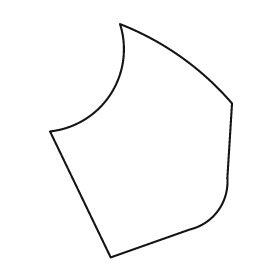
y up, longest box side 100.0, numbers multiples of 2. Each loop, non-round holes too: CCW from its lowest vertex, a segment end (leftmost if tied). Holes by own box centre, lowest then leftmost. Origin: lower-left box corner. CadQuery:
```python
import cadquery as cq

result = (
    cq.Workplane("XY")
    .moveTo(26.0, 0.0)
    .lineTo(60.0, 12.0)
    .threePointArc((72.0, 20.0), (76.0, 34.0))
    .lineTo(78.0, 66.0)
    .threePointArc((56.0, 86.0), (30.0, 100.0))
    .threePointArc((26.0, 70.0), (0.0, 54.0))
    .close()
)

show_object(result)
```